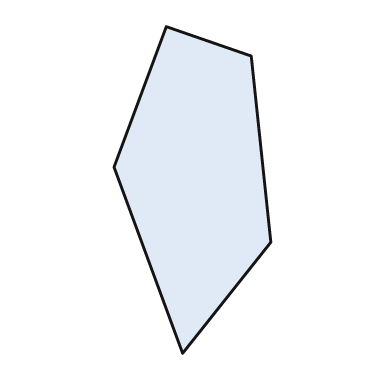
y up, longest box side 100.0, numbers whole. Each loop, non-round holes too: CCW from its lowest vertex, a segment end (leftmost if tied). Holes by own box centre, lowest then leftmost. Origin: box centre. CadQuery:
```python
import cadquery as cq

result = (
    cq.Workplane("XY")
    .moveTo(-3.0, -50.0)
    .lineTo(24.0, -16.0)
    .lineTo(18.0, 41.0)
    .lineTo(-8.0, 50.0)
    .lineTo(-24.0, 7.0)
    .close()
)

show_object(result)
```